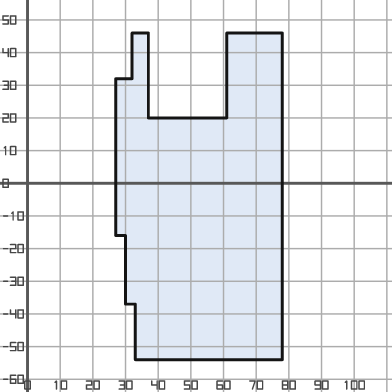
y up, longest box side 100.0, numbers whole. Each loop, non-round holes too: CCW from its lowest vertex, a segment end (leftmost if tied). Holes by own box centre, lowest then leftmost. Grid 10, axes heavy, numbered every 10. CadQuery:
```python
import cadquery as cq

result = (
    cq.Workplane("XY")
    .moveTo(33.0, -54.0)
    .lineTo(78.0, -54.0)
    .lineTo(78.0, 46.0)
    .lineTo(61.0, 46.0)
    .lineTo(61.0, 20.0)
    .lineTo(37.0, 20.0)
    .lineTo(37.0, 46.0)
    .lineTo(32.0, 46.0)
    .lineTo(32.0, 32.0)
    .lineTo(27.0, 32.0)
    .lineTo(27.0, -16.0)
    .lineTo(30.0, -16.0)
    .lineTo(30.0, -37.0)
    .lineTo(33.0, -37.0)
    .close()
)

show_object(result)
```